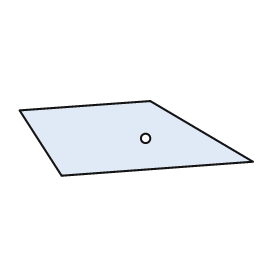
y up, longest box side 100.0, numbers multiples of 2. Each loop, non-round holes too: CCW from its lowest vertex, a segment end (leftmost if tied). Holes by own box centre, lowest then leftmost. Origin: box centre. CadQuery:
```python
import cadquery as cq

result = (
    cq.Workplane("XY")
    .moveTo(-32.0, -16.0)
    .lineTo(50.0, -10.0)
    .lineTo(6.0, 16.0)
    .lineTo(-50.0, 12.0)
    .close()
    .moveTo(4.0, 0.0)
    .circle(2.0)
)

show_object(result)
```